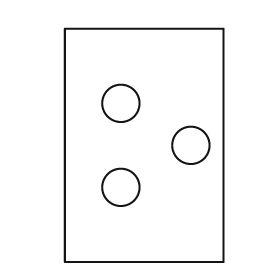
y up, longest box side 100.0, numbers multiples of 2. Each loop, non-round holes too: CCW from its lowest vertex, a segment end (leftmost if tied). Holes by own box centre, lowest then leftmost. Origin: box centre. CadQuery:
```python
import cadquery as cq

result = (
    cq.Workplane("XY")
    .moveTo(-34.0, -50.0)
    .lineTo(34.0, -50.0)
    .lineTo(34.0, 50.0)
    .lineTo(-34.0, 50.0)
    .close()
    .moveTo(-10.0, -18.0)
    .circle(8.0)
    .moveTo(20.0, 0.0)
    .circle(8.0)
    .moveTo(-10.0, 18.0)
    .circle(8.0)
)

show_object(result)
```